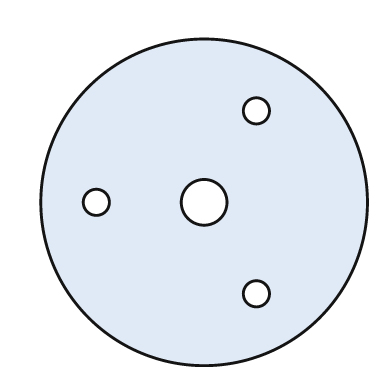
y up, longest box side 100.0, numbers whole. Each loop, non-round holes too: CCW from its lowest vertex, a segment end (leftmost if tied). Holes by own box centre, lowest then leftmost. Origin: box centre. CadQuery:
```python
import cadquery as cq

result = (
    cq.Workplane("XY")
    .moveTo(0.0, 0.0)
    .circle(50.0)
    .moveTo(16.0, -28.0)
    .circle(4.0)
    .moveTo(-33.0, 0.0)
    .circle(4.0)
    .moveTo(0.0, 0.0)
    .circle(7.0)
    .moveTo(16.0, 28.0)
    .circle(4.0)
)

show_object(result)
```